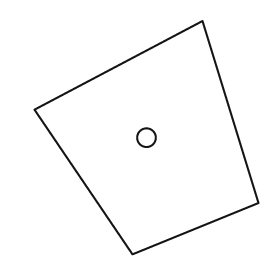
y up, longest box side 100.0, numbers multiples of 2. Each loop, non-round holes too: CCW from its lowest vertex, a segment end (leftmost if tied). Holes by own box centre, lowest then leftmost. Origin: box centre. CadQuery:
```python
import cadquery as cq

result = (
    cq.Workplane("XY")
    .moveTo(-6.0, -50.0)
    .lineTo(48.0, -28.0)
    .lineTo(24.0, 50.0)
    .lineTo(-48.0, 12.0)
    .close()
    .moveTo(0.0, 0.0)
    .circle(4.0)
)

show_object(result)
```